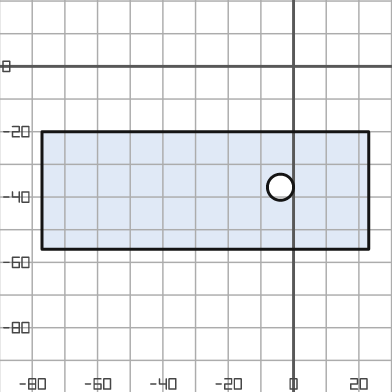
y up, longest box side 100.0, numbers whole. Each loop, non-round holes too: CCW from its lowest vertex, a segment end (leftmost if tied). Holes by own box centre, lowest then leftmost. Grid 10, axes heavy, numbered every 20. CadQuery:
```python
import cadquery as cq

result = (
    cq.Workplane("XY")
    .moveTo(-77.0, -56.0)
    .lineTo(23.0, -56.0)
    .lineTo(23.0, -20.0)
    .lineTo(-77.0, -20.0)
    .close()
    .moveTo(-4.0, -37.0)
    .circle(4.0)
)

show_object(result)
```